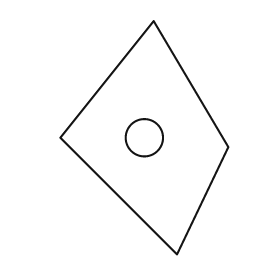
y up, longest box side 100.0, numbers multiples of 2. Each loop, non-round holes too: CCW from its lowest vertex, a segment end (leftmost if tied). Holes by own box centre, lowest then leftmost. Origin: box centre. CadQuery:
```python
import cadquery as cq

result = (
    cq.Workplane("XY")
    .moveTo(14.0, -50.0)
    .lineTo(36.0, -4.0)
    .lineTo(4.0, 50.0)
    .lineTo(-36.0, 0.0)
    .close()
    .moveTo(0.0, 0.0)
    .circle(8.0)
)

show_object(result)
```